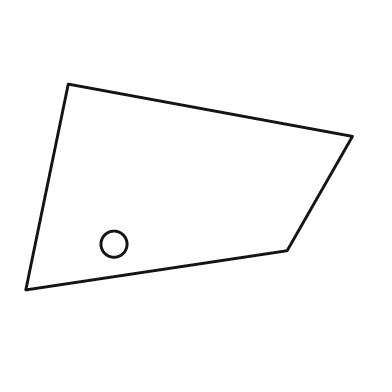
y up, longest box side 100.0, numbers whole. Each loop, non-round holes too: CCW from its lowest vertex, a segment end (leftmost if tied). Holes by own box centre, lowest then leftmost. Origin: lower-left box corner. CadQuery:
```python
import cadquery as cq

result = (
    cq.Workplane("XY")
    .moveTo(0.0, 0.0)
    .lineTo(80.0, 12.0)
    .lineTo(100.0, 47.0)
    .lineTo(13.0, 63.0)
    .close()
    .moveTo(27.0, 14.0)
    .circle(4.0)
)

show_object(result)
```